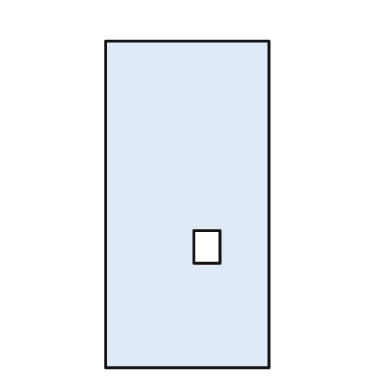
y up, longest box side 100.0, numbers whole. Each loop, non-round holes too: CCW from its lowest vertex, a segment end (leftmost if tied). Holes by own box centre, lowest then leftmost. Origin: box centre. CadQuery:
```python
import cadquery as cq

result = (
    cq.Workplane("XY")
    .moveTo(-25.0, -50.0)
    .lineTo(25.0, -50.0)
    .lineTo(25.0, 50.0)
    .lineTo(-25.0, 50.0)
    .close()
    .moveTo(2.0, -18.0)
    .lineTo(10.0, -18.0)
    .lineTo(10.0, -8.0)
    .lineTo(2.0, -8.0)
    .close()
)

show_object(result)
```